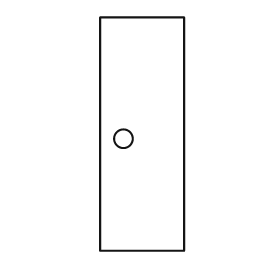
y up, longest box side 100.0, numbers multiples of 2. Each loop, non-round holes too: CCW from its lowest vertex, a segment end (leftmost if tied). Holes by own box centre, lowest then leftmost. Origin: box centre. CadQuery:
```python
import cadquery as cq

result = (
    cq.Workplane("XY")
    .moveTo(-18.0, -50.0)
    .lineTo(18.0, -50.0)
    .lineTo(18.0, 50.0)
    .lineTo(-18.0, 50.0)
    .close()
    .moveTo(-8.0, -2.0)
    .circle(4.0)
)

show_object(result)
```